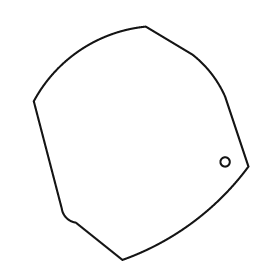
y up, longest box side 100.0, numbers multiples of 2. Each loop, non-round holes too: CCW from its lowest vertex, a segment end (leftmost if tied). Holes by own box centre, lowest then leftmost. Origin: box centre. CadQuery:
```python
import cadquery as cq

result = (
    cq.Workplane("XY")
    .moveTo(-8.0, -50.0)
    .threePointArc((22.0, -34.0), (46.0, -10.0))
    .lineTo(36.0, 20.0)
    .threePointArc((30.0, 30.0), (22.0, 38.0))
    .lineTo(2.0, 50.0)
    .threePointArc((-26.0, 40.0), (-46.0, 18.0))
    .lineTo(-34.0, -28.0)
    .threePointArc((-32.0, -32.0), (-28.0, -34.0))
    .close()
    .moveTo(36.0, -8.0)
    .circle(2.0)
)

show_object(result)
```